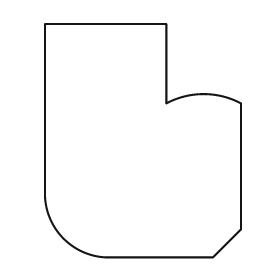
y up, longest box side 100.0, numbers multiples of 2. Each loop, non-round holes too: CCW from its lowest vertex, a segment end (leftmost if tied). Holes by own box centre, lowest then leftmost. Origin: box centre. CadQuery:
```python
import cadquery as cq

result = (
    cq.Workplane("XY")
    .moveTo(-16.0, -50.0)
    .lineTo(30.0, -50.0)
    .lineTo(42.0, -38.0)
    .lineTo(42.0, 16.0)
    .threePointArc((26.0, 20.0), (10.0, 16.0))
    .lineTo(10.0, 50.0)
    .lineTo(-42.0, 50.0)
    .lineTo(-42.0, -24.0)
    .threePointArc((-34.0, -42.0), (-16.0, -50.0))
    .close()
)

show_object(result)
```